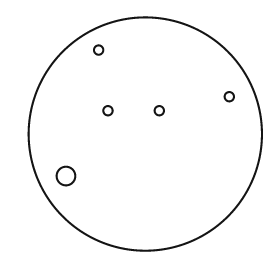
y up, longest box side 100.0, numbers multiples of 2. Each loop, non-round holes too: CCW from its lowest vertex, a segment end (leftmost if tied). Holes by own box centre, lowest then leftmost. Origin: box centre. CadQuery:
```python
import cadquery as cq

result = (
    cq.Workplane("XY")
    .moveTo(0.0, 0.0)
    .circle(50.0)
    .moveTo(-34.0, -18.0)
    .circle(4.0)
    .moveTo(-16.0, 10.0)
    .circle(2.0)
    .moveTo(6.0, 10.0)
    .circle(2.0)
    .moveTo(36.0, 16.0)
    .circle(2.0)
    .moveTo(-20.0, 36.0)
    .circle(2.0)
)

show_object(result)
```